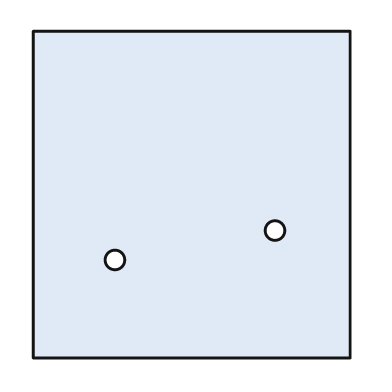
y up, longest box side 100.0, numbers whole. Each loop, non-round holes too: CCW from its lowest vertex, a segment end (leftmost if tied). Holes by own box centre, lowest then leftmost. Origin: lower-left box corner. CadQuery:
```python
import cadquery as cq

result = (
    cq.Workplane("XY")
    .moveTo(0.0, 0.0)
    .lineTo(97.0, 0.0)
    .lineTo(97.0, 100.0)
    .lineTo(0.0, 100.0)
    .close()
    .moveTo(25.0, 30.0)
    .circle(3.0)
    .moveTo(74.0, 39.0)
    .circle(3.0)
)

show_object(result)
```